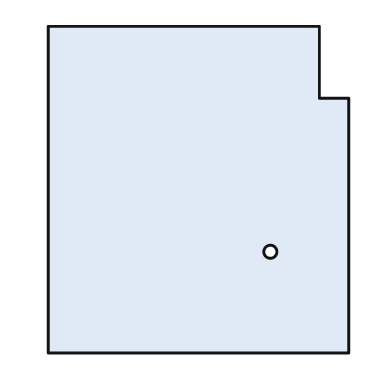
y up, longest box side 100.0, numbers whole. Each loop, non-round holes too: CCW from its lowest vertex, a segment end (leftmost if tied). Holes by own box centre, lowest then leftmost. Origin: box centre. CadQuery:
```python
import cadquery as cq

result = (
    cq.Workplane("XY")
    .moveTo(-46.0, -50.0)
    .lineTo(46.0, -50.0)
    .lineTo(46.0, 28.0)
    .lineTo(37.0, 28.0)
    .lineTo(37.0, 50.0)
    .lineTo(-46.0, 50.0)
    .close()
    .moveTo(22.0, -19.0)
    .circle(2.0)
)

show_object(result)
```